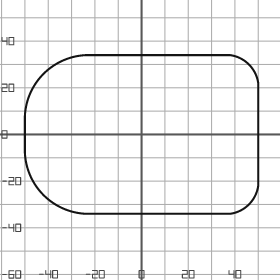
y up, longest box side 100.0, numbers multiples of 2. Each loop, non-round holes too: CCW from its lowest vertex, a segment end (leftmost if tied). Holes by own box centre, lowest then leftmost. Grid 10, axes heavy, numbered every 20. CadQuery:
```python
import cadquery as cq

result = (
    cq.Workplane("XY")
    .moveTo(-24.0, -34.0)
    .lineTo(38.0, -34.0)
    .threePointArc((46.0, -30.0), (50.0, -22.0))
    .lineTo(50.0, 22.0)
    .threePointArc((46.0, 30.0), (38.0, 34.0))
    .lineTo(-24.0, 34.0)
    .threePointArc((-42.0, 26.0), (-50.0, 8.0))
    .lineTo(-50.0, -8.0)
    .threePointArc((-42.0, -26.0), (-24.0, -34.0))
    .close()
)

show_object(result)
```